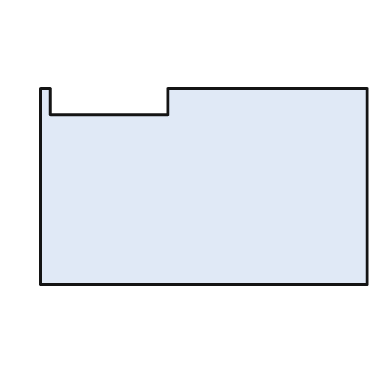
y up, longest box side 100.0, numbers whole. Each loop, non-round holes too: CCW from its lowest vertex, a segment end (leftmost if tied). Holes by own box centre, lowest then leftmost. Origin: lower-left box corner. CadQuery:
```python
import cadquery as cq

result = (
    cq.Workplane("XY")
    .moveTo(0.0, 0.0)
    .lineTo(100.0, 0.0)
    .lineTo(100.0, 60.0)
    .lineTo(39.0, 60.0)
    .lineTo(39.0, 52.0)
    .lineTo(3.0, 52.0)
    .lineTo(3.0, 60.0)
    .lineTo(0.0, 60.0)
    .close()
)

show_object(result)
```